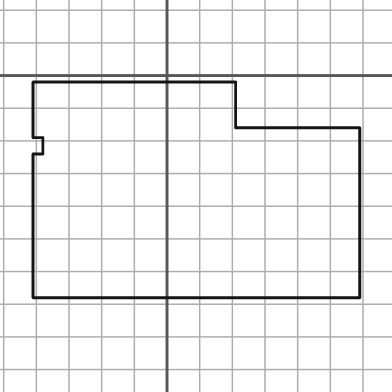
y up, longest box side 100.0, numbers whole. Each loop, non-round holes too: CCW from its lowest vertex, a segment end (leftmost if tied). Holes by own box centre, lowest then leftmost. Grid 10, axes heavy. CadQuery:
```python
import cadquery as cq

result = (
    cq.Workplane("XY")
    .moveTo(-41.0, -68.0)
    .lineTo(59.0, -68.0)
    .lineTo(59.0, -16.0)
    .lineTo(21.0, -16.0)
    .lineTo(21.0, -2.0)
    .lineTo(-41.0, -2.0)
    .lineTo(-41.0, -19.0)
    .lineTo(-38.0, -19.0)
    .lineTo(-38.0, -24.0)
    .lineTo(-41.0, -24.0)
    .close()
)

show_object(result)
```